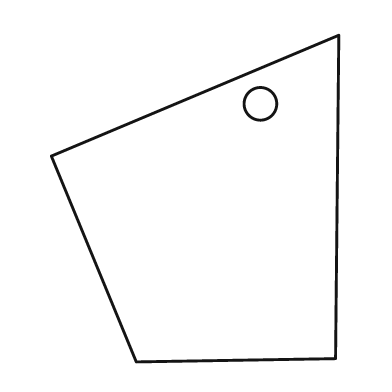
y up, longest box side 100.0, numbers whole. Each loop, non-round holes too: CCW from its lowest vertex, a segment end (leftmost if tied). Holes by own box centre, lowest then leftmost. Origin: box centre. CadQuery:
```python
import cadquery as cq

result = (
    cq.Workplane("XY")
    .moveTo(-18.0, -50.0)
    .lineTo(43.0, -49.0)
    .lineTo(44.0, 50.0)
    .lineTo(-44.0, 13.0)
    .close()
    .moveTo(20.0, 29.0)
    .circle(5.0)
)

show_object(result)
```